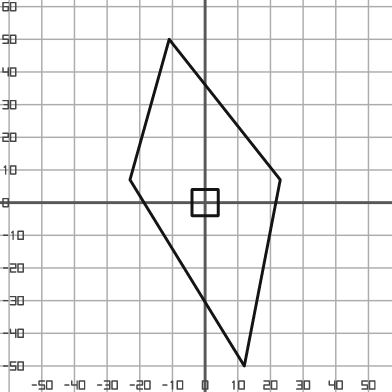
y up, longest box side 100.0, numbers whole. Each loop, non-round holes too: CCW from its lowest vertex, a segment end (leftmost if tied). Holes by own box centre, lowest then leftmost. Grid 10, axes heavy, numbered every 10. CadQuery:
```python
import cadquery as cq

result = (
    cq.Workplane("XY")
    .moveTo(12.0, -50.0)
    .lineTo(23.0, 7.0)
    .lineTo(-11.0, 50.0)
    .lineTo(-23.0, 7.0)
    .close()
    .moveTo(-4.0, -4.0)
    .lineTo(4.0, -4.0)
    .lineTo(4.0, 4.0)
    .lineTo(-4.0, 4.0)
    .close()
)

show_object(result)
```